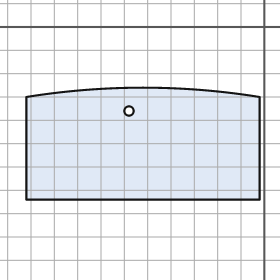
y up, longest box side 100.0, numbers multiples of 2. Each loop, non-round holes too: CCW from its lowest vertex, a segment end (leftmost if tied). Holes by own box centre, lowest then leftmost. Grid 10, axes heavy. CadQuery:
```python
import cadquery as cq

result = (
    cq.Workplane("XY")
    .moveTo(-102.0, -74.0)
    .lineTo(-2.0, -74.0)
    .lineTo(-2.0, -30.0)
    .threePointArc((-52.0, -26.0), (-102.0, -30.0))
    .close()
    .moveTo(-58.0, -36.0)
    .circle(2.0)
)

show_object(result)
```